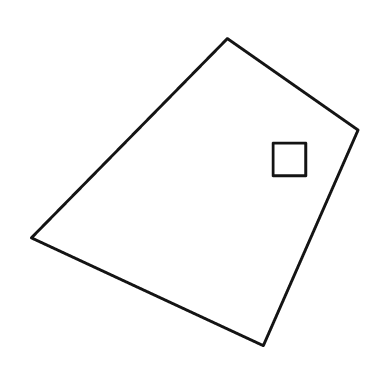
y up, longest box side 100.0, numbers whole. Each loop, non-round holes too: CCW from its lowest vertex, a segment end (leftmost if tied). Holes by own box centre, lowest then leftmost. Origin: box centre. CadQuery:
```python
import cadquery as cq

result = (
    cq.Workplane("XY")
    .moveTo(21.0, -47.0)
    .lineTo(50.0, 19.0)
    .lineTo(10.0, 47.0)
    .lineTo(-50.0, -14.0)
    .close()
    .moveTo(24.0, 5.0)
    .lineTo(34.0, 5.0)
    .lineTo(34.0, 15.0)
    .lineTo(24.0, 15.0)
    .close()
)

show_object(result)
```